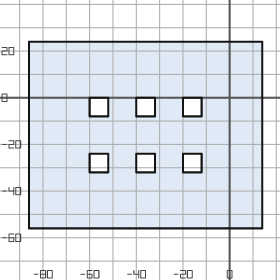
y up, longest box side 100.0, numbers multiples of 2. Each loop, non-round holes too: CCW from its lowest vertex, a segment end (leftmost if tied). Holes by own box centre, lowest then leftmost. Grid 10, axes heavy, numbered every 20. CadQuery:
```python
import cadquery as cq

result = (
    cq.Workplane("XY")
    .moveTo(-86.0, -56.0)
    .lineTo(14.0, -56.0)
    .lineTo(14.0, 24.0)
    .lineTo(-86.0, 24.0)
    .close()
    .moveTo(-60.0, -32.0)
    .lineTo(-52.0, -32.0)
    .lineTo(-52.0, -24.0)
    .lineTo(-60.0, -24.0)
    .close()
    .moveTo(-40.0, -32.0)
    .lineTo(-32.0, -32.0)
    .lineTo(-32.0, -24.0)
    .lineTo(-40.0, -24.0)
    .close()
    .moveTo(-20.0, -32.0)
    .lineTo(-12.0, -32.0)
    .lineTo(-12.0, -24.0)
    .lineTo(-20.0, -24.0)
    .close()
    .moveTo(-60.0, -8.0)
    .lineTo(-52.0, -8.0)
    .lineTo(-52.0, 0.0)
    .lineTo(-60.0, 0.0)
    .close()
    .moveTo(-40.0, -8.0)
    .lineTo(-32.0, -8.0)
    .lineTo(-32.0, 0.0)
    .lineTo(-40.0, 0.0)
    .close()
    .moveTo(-20.0, -8.0)
    .lineTo(-12.0, -8.0)
    .lineTo(-12.0, 0.0)
    .lineTo(-20.0, 0.0)
    .close()
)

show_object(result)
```